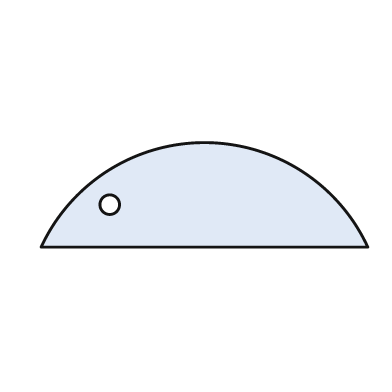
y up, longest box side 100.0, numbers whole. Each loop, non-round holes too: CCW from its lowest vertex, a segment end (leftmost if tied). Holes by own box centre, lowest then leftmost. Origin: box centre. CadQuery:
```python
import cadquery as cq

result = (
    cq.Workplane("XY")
    .moveTo(-50.0, -16.0)
    .lineTo(50.0, -16.0)
    .threePointArc((0.0, 16.0), (-50.0, -16.0))
    .close()
    .moveTo(-29.0, -3.0)
    .circle(3.0)
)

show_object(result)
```